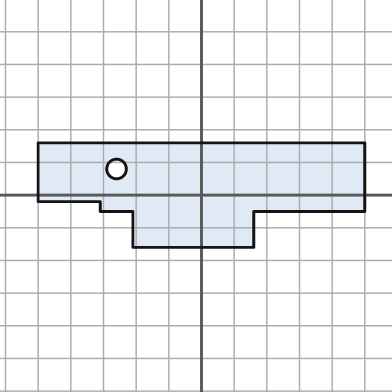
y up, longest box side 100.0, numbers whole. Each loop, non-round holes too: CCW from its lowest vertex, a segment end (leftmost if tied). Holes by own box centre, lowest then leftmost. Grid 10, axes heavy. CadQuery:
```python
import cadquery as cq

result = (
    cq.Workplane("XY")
    .moveTo(-21.0, -16.0)
    .lineTo(16.0, -16.0)
    .lineTo(16.0, -5.0)
    .lineTo(50.0, -5.0)
    .lineTo(50.0, 16.0)
    .lineTo(-50.0, 16.0)
    .lineTo(-50.0, -2.0)
    .lineTo(-31.0, -2.0)
    .lineTo(-31.0, -5.0)
    .lineTo(-21.0, -5.0)
    .close()
    .moveTo(-26.0, 8.0)
    .circle(3.0)
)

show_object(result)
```